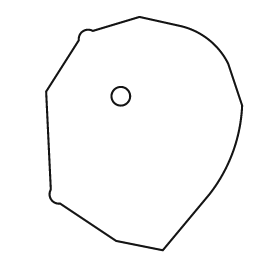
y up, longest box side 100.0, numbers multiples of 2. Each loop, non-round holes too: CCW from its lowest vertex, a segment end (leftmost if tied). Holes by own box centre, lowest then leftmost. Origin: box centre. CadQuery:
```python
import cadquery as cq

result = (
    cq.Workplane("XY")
    .moveTo(8.0, -50.0)
    .lineTo(28.0, -26.0)
    .threePointArc((38.0, -8.0), (42.0, 12.0))
    .lineTo(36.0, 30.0)
    .threePointArc((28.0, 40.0), (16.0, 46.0))
    .lineTo(-2.0, 50.0)
    .lineTo(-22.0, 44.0)
    .threePointArc((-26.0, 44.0), (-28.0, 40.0))
    .lineTo(-42.0, 18.0)
    .lineTo(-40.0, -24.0)
    .threePointArc((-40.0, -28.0), (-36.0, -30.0))
    .lineTo(-12.0, -46.0)
    .close()
    .moveTo(-10.0, 16.0)
    .circle(4.0)
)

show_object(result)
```